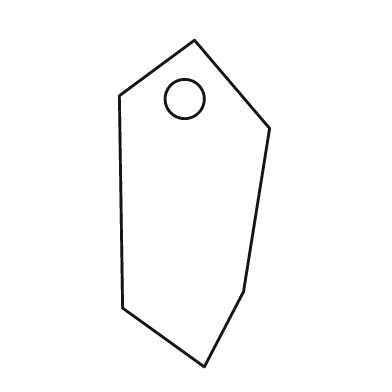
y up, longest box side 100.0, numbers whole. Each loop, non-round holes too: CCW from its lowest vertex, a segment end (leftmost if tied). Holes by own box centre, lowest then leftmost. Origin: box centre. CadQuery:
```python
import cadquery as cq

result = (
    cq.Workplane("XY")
    .moveTo(3.0, -50.0)
    .lineTo(15.0, -27.0)
    .lineTo(23.0, 23.0)
    .lineTo(0.0, 50.0)
    .lineTo(-23.0, 33.0)
    .lineTo(-22.0, -32.0)
    .close()
    .moveTo(-3.0, 32.0)
    .circle(6.0)
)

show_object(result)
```